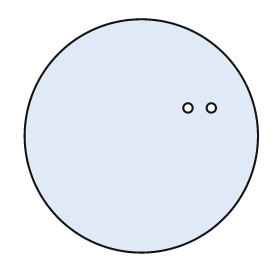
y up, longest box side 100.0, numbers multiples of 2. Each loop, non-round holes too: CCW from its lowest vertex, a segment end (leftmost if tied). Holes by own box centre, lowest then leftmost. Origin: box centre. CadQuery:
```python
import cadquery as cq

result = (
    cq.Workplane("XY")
    .moveTo(0.0, 0.0)
    .circle(50.0)
    .moveTo(20.0, 12.0)
    .circle(2.0)
    .moveTo(30.0, 12.0)
    .circle(2.0)
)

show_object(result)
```